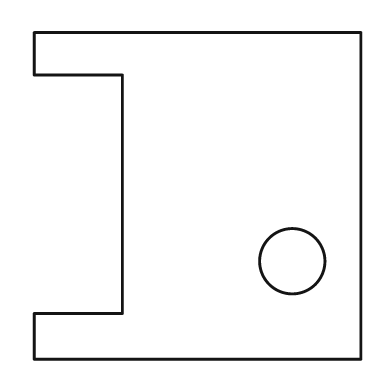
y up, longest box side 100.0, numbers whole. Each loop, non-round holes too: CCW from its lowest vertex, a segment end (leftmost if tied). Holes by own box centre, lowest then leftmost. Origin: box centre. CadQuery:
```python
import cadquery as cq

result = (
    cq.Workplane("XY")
    .moveTo(-50.0, -50.0)
    .lineTo(50.0, -50.0)
    .lineTo(50.0, 50.0)
    .lineTo(-50.0, 50.0)
    .lineTo(-50.0, 37.0)
    .lineTo(-23.0, 37.0)
    .lineTo(-23.0, -36.0)
    .lineTo(-50.0, -36.0)
    .close()
    .moveTo(29.0, -20.0)
    .circle(10.0)
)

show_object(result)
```